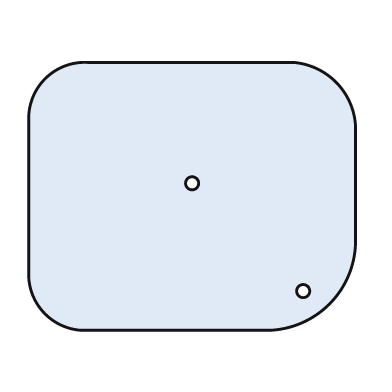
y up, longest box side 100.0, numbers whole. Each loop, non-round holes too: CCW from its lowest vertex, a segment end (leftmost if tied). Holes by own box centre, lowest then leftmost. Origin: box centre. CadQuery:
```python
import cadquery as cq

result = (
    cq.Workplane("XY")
    .moveTo(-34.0, -41.0)
    .lineTo(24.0, -41.0)
    .threePointArc((42.0, -33.0), (50.0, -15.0))
    .lineTo(50.0, 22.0)
    .threePointArc((44.0, 35.0), (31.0, 41.0))
    .lineTo(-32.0, 41.0)
    .threePointArc((-45.0, 36.0), (-50.0, 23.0))
    .lineTo(-50.0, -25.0)
    .threePointArc((-45.0, -36.0), (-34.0, -41.0))
    .close()
    .moveTo(34.0, -29.0)
    .circle(2.0)
    .moveTo(0.0, 4.0)
    .circle(2.0)
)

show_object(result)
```